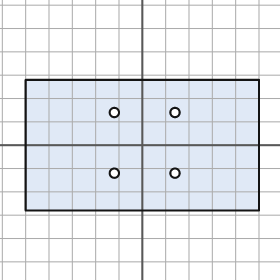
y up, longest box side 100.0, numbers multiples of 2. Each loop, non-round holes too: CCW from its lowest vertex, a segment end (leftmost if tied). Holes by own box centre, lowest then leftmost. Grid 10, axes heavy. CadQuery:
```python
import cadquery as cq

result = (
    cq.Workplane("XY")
    .moveTo(-50.0, -28.0)
    .lineTo(50.0, -28.0)
    .lineTo(50.0, 28.0)
    .lineTo(-50.0, 28.0)
    .close()
    .moveTo(-12.0, -12.0)
    .circle(2.0)
    .moveTo(14.0, -12.0)
    .circle(2.0)
    .moveTo(-12.0, 14.0)
    .circle(2.0)
    .moveTo(14.0, 14.0)
    .circle(2.0)
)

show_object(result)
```